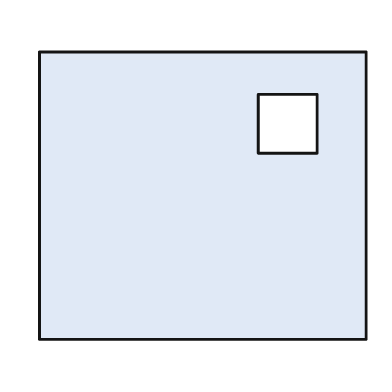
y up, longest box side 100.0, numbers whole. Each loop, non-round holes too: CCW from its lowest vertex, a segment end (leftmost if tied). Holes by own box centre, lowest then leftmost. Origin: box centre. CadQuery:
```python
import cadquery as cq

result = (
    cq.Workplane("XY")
    .moveTo(-50.0, -44.0)
    .lineTo(50.0, -44.0)
    .lineTo(50.0, 44.0)
    .lineTo(-50.0, 44.0)
    .close()
    .moveTo(17.0, 13.0)
    .lineTo(35.0, 13.0)
    .lineTo(35.0, 31.0)
    .lineTo(17.0, 31.0)
    .close()
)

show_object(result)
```